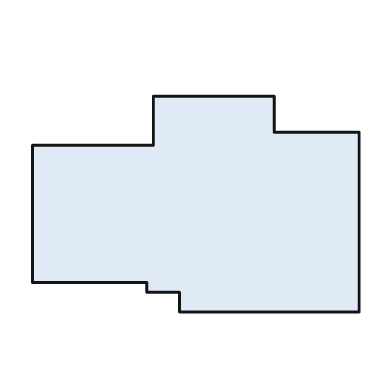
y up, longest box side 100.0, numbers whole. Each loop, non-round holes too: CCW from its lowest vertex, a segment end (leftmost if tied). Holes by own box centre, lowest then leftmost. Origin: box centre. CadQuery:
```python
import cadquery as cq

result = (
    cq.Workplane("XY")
    .moveTo(-5.0, -33.0)
    .lineTo(50.0, -33.0)
    .lineTo(50.0, 22.0)
    .lineTo(24.0, 22.0)
    .lineTo(24.0, 33.0)
    .lineTo(-13.0, 33.0)
    .lineTo(-13.0, 18.0)
    .lineTo(-50.0, 18.0)
    .lineTo(-50.0, -24.0)
    .lineTo(-15.0, -24.0)
    .lineTo(-15.0, -27.0)
    .lineTo(-5.0, -27.0)
    .close()
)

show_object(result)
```